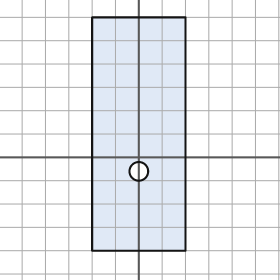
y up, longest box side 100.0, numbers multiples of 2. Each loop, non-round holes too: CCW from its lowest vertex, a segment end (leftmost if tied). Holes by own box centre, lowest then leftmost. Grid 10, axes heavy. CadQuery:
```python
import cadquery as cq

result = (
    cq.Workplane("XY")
    .moveTo(-20.0, -40.0)
    .lineTo(20.0, -40.0)
    .lineTo(20.0, 60.0)
    .lineTo(-20.0, 60.0)
    .close()
    .moveTo(0.0, -6.0)
    .circle(4.0)
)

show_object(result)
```